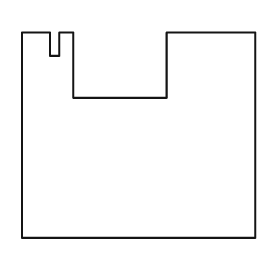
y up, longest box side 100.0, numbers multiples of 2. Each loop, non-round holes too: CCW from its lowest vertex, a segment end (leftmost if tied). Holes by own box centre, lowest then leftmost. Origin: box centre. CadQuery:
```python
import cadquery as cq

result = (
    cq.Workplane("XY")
    .moveTo(-50.0, -44.0)
    .lineTo(50.0, -44.0)
    .lineTo(50.0, 44.0)
    .lineTo(12.0, 44.0)
    .lineTo(12.0, 16.0)
    .lineTo(-28.0, 16.0)
    .lineTo(-28.0, 44.0)
    .lineTo(-34.0, 44.0)
    .lineTo(-34.0, 34.0)
    .lineTo(-38.0, 34.0)
    .lineTo(-38.0, 44.0)
    .lineTo(-50.0, 44.0)
    .close()
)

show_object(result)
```